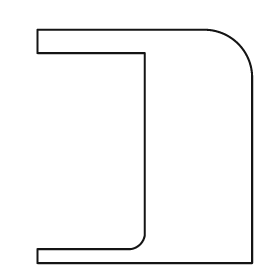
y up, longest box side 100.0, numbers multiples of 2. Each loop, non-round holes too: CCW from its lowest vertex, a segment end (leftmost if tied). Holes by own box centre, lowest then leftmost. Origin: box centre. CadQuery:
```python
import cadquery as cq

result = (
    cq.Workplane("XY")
    .moveTo(-46.0, -50.0)
    .lineTo(46.0, -50.0)
    .lineTo(46.0, 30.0)
    .threePointArc((40.0, 44.0), (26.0, 50.0))
    .lineTo(-46.0, 50.0)
    .lineTo(-46.0, 40.0)
    .lineTo(0.0, 40.0)
    .lineTo(0.0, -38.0)
    .threePointArc((-2.0, -42.0), (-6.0, -44.0))
    .lineTo(-46.0, -44.0)
    .close()
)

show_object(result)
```